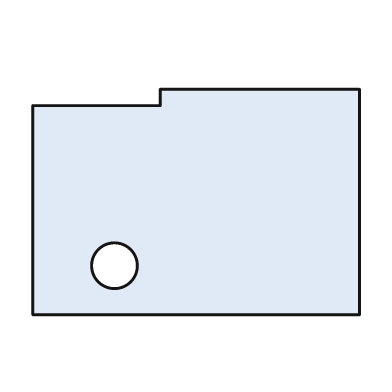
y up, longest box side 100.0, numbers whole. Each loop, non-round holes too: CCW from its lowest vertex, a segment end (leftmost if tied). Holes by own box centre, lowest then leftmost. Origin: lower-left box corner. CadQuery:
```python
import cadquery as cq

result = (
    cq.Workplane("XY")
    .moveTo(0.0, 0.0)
    .lineTo(100.0, 0.0)
    .lineTo(100.0, 69.0)
    .lineTo(39.0, 69.0)
    .lineTo(39.0, 64.0)
    .lineTo(0.0, 64.0)
    .close()
    .moveTo(25.0, 15.0)
    .circle(7.0)
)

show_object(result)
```